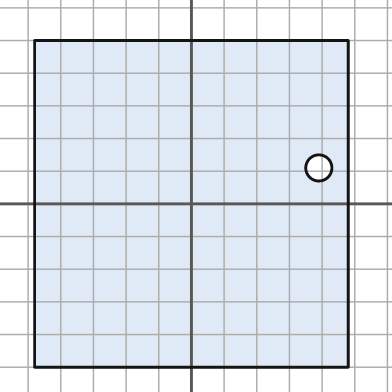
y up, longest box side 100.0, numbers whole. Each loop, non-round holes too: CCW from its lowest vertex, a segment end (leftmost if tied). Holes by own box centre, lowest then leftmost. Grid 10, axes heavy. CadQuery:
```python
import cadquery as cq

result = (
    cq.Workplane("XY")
    .moveTo(-48.0, -50.0)
    .lineTo(48.0, -50.0)
    .lineTo(48.0, 50.0)
    .lineTo(-48.0, 50.0)
    .close()
    .moveTo(39.0, 11.0)
    .circle(4.0)
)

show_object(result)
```